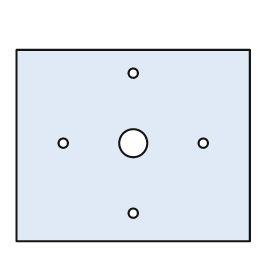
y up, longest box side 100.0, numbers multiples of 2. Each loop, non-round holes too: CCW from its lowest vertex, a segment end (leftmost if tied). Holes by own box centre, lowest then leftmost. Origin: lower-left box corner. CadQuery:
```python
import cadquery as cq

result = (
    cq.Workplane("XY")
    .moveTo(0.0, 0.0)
    .lineTo(100.0, 0.0)
    .lineTo(100.0, 82.0)
    .lineTo(0.0, 82.0)
    .close()
    .moveTo(50.0, 12.0)
    .circle(2.0)
    .moveTo(20.0, 42.0)
    .circle(2.0)
    .moveTo(50.0, 42.0)
    .circle(6.0)
    .moveTo(80.0, 42.0)
    .circle(2.0)
    .moveTo(50.0, 72.0)
    .circle(2.0)
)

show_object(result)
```